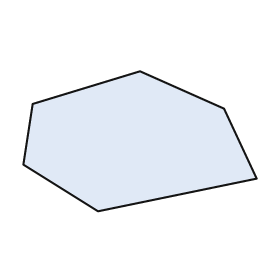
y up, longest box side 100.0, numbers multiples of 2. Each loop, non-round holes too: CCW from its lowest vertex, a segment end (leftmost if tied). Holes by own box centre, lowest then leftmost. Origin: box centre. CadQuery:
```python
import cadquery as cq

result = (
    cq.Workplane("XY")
    .moveTo(-18.0, -30.0)
    .lineTo(50.0, -16.0)
    .lineTo(36.0, 14.0)
    .lineTo(0.0, 30.0)
    .lineTo(-46.0, 16.0)
    .lineTo(-50.0, -10.0)
    .close()
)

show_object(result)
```